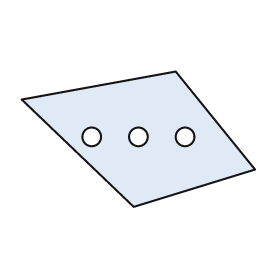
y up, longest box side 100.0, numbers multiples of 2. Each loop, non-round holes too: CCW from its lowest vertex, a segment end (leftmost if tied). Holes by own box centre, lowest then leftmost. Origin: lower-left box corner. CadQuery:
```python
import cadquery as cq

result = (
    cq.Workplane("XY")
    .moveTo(48.0, 0.0)
    .lineTo(100.0, 16.0)
    .lineTo(66.0, 58.0)
    .lineTo(0.0, 46.0)
    .close()
    .moveTo(30.0, 30.0)
    .circle(4.0)
    .moveTo(50.0, 30.0)
    .circle(4.0)
    .moveTo(70.0, 30.0)
    .circle(4.0)
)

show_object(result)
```